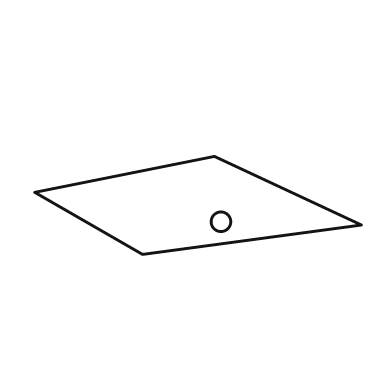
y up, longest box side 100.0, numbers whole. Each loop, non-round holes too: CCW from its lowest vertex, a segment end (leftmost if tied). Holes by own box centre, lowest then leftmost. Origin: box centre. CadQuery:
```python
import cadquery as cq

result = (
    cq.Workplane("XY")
    .moveTo(-17.0, -15.0)
    .lineTo(50.0, -6.0)
    .lineTo(5.0, 15.0)
    .lineTo(-50.0, 4.0)
    .close()
    .moveTo(7.0, -5.0)
    .circle(3.0)
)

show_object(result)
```